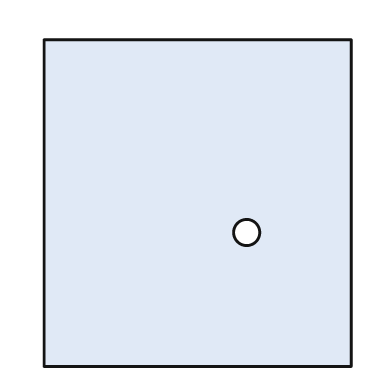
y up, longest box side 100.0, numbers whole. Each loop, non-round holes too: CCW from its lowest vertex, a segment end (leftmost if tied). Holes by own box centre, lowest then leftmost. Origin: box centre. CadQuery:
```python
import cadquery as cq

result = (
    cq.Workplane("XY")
    .moveTo(-47.0, -50.0)
    .lineTo(47.0, -50.0)
    .lineTo(47.0, 50.0)
    .lineTo(-47.0, 50.0)
    .close()
    .moveTo(15.0, -9.0)
    .circle(4.0)
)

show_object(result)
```